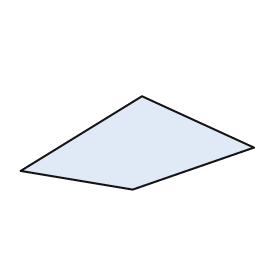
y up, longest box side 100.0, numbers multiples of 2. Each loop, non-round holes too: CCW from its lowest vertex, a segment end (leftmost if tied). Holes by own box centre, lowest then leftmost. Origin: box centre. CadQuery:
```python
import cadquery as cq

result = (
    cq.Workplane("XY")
    .moveTo(-2.0, -20.0)
    .lineTo(50.0, -2.0)
    .lineTo(2.0, 20.0)
    .lineTo(-50.0, -12.0)
    .close()
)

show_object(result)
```